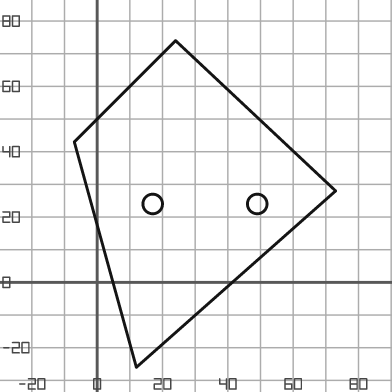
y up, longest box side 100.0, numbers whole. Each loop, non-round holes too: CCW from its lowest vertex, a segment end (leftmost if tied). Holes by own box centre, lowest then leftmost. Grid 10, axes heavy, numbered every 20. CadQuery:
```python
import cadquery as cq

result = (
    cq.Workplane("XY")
    .moveTo(12.0, -26.0)
    .lineTo(73.0, 28.0)
    .lineTo(24.0, 74.0)
    .lineTo(-7.0, 43.0)
    .close()
    .moveTo(17.0, 24.0)
    .circle(3.0)
    .moveTo(49.0, 24.0)
    .circle(3.0)
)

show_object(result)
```